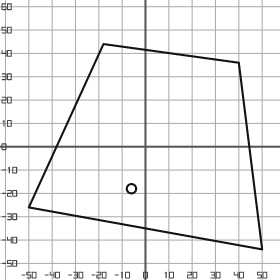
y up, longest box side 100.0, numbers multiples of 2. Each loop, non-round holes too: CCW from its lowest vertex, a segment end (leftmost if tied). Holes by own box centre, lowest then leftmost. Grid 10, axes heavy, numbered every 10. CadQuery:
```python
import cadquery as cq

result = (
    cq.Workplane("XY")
    .moveTo(50.0, -44.0)
    .lineTo(40.0, 36.0)
    .lineTo(-18.0, 44.0)
    .lineTo(-50.0, -26.0)
    .close()
    .moveTo(-6.0, -18.0)
    .circle(2.0)
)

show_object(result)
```